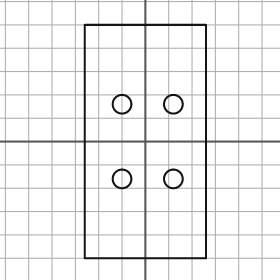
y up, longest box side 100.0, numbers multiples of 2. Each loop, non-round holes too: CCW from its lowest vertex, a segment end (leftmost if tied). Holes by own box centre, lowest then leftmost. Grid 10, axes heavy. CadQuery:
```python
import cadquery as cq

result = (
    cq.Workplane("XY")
    .moveTo(-26.0, -50.0)
    .lineTo(26.0, -50.0)
    .lineTo(26.0, 50.0)
    .lineTo(-26.0, 50.0)
    .close()
    .moveTo(-10.0, -16.0)
    .circle(4.0)
    .moveTo(12.0, -16.0)
    .circle(4.0)
    .moveTo(-10.0, 16.0)
    .circle(4.0)
    .moveTo(12.0, 16.0)
    .circle(4.0)
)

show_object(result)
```